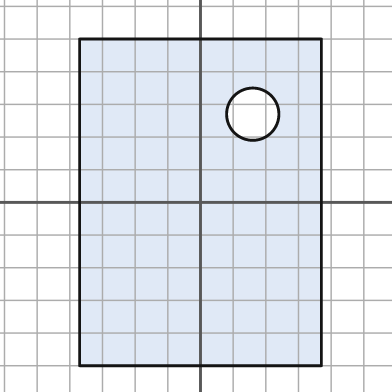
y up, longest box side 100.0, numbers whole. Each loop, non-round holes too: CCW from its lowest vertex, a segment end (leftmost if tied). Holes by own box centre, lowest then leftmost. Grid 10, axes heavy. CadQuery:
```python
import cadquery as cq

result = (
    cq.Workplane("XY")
    .moveTo(-37.0, -50.0)
    .lineTo(37.0, -50.0)
    .lineTo(37.0, 50.0)
    .lineTo(-37.0, 50.0)
    .close()
    .moveTo(16.0, 27.0)
    .circle(8.0)
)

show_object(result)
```